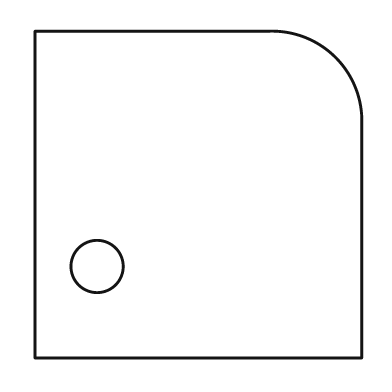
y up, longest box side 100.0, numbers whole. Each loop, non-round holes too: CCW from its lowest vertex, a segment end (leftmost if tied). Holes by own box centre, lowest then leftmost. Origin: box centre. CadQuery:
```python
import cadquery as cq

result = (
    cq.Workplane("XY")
    .moveTo(-50.0, -50.0)
    .lineTo(50.0, -50.0)
    .lineTo(50.0, 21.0)
    .threePointArc((42.0, 42.0), (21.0, 50.0))
    .lineTo(-50.0, 50.0)
    .close()
    .moveTo(-31.0, -22.0)
    .circle(8.0)
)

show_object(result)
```